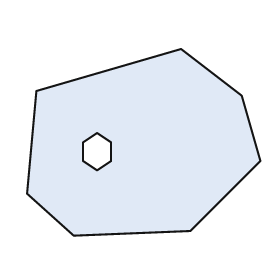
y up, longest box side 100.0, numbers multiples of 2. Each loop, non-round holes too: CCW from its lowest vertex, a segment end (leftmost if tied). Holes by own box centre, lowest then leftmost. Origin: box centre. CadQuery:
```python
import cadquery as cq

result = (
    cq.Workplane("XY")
    .moveTo(-30.0, -40.0)
    .lineTo(20.0, -38.0)
    .lineTo(50.0, -8.0)
    .lineTo(42.0, 20.0)
    .lineTo(16.0, 40.0)
    .lineTo(-46.0, 22.0)
    .lineTo(-50.0, -22.0)
    .close()
    .moveTo(-20.0, -12.0)
    .lineTo(-14.0, -8.0)
    .lineTo(-14.0, 0.0)
    .lineTo(-20.0, 4.0)
    .lineTo(-26.0, 0.0)
    .lineTo(-26.0, -8.0)
    .close()
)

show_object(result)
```